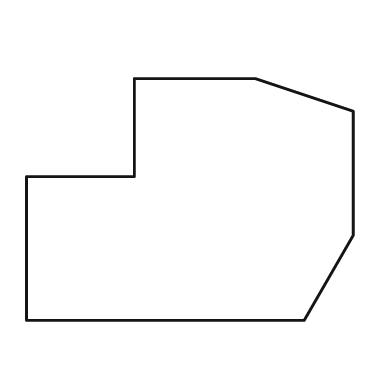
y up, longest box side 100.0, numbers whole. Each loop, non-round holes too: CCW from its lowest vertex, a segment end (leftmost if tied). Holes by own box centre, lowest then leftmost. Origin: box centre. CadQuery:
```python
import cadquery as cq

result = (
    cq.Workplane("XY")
    .moveTo(-50.0, -37.0)
    .lineTo(35.0, -37.0)
    .lineTo(50.0, -11.0)
    .lineTo(50.0, 27.0)
    .lineTo(20.0, 37.0)
    .lineTo(-17.0, 37.0)
    .lineTo(-17.0, 7.0)
    .lineTo(-50.0, 7.0)
    .close()
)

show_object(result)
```